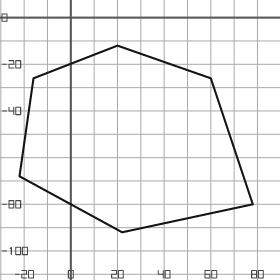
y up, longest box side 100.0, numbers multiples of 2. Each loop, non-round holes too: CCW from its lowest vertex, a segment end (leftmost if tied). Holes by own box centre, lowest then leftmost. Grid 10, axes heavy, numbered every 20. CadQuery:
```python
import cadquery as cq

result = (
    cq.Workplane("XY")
    .moveTo(22.0, -92.0)
    .lineTo(78.0, -80.0)
    .lineTo(60.0, -26.0)
    .lineTo(20.0, -12.0)
    .lineTo(-16.0, -26.0)
    .lineTo(-22.0, -68.0)
    .close()
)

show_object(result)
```